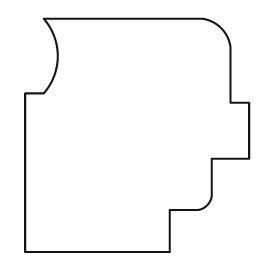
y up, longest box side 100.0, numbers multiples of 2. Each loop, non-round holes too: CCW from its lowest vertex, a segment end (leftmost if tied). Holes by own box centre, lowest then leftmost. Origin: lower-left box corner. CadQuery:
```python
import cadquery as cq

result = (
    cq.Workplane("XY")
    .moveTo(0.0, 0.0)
    .lineTo(62.0, 0.0)
    .lineTo(62.0, 18.0)
    .lineTo(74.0, 18.0)
    .threePointArc((78.0, 20.0), (80.0, 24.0))
    .lineTo(80.0, 40.0)
    .lineTo(96.0, 40.0)
    .lineTo(96.0, 64.0)
    .lineTo(88.0, 64.0)
    .lineTo(88.0, 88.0)
    .threePointArc((84.0, 96.0), (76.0, 100.0))
    .lineTo(8.0, 100.0)
    .threePointArc((14.0, 84.0), (8.0, 68.0))
    .lineTo(0.0, 68.0)
    .close()
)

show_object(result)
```